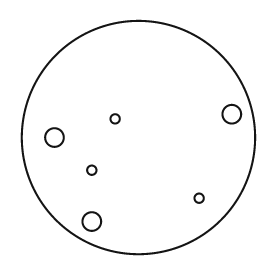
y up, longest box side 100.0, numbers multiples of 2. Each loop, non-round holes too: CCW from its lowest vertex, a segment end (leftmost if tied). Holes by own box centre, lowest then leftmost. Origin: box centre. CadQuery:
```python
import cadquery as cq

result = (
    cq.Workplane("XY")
    .moveTo(0.0, 0.0)
    .circle(50.0)
    .moveTo(-20.0, -36.0)
    .circle(4.0)
    .moveTo(26.0, -26.0)
    .circle(2.0)
    .moveTo(-20.0, -14.0)
    .circle(2.0)
    .moveTo(-36.0, 0.0)
    .circle(4.0)
    .moveTo(-10.0, 8.0)
    .circle(2.0)
    .moveTo(40.0, 10.0)
    .circle(4.0)
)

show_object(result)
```